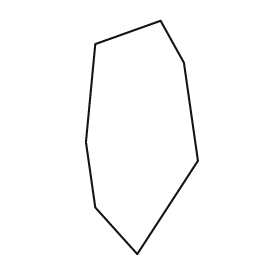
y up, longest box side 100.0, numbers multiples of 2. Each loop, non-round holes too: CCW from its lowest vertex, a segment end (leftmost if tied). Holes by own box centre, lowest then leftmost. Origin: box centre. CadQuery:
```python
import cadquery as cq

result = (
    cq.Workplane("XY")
    .moveTo(-2.0, -50.0)
    .lineTo(24.0, -10.0)
    .lineTo(18.0, 32.0)
    .lineTo(8.0, 50.0)
    .lineTo(-20.0, 40.0)
    .lineTo(-24.0, -2.0)
    .lineTo(-20.0, -30.0)
    .close()
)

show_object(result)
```